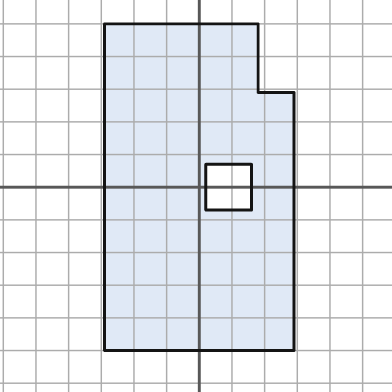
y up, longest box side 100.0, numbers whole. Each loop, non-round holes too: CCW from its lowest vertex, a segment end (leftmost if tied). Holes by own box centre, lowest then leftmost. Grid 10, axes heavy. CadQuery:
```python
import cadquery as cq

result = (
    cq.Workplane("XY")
    .moveTo(-29.0, -50.0)
    .lineTo(29.0, -50.0)
    .lineTo(29.0, 29.0)
    .lineTo(18.0, 29.0)
    .lineTo(18.0, 50.0)
    .lineTo(-29.0, 50.0)
    .close()
    .moveTo(2.0, -7.0)
    .lineTo(16.0, -7.0)
    .lineTo(16.0, 7.0)
    .lineTo(2.0, 7.0)
    .close()
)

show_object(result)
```